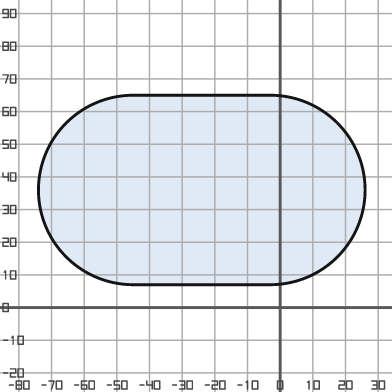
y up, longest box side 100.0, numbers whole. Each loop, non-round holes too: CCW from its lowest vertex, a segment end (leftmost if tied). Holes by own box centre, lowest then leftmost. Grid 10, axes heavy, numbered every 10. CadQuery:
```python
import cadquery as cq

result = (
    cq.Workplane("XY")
    .moveTo(-45.0, 7.0)
    .lineTo(-3.0, 7.0)
    .threePointArc((26.0, 36.0), (-3.0, 65.0))
    .lineTo(-45.0, 65.0)
    .threePointArc((-74.0, 36.0), (-45.0, 7.0))
    .close()
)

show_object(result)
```